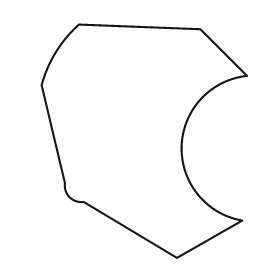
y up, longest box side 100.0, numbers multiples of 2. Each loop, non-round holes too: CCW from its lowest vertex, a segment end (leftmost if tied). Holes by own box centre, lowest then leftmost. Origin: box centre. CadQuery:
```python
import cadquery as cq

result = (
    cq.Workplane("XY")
    .moveTo(14.0, -50.0)
    .lineTo(42.0, -34.0)
    .threePointArc((16.0, -2.0), (44.0, 28.0))
    .lineTo(24.0, 48.0)
    .lineTo(-28.0, 50.0)
    .threePointArc((-38.0, 38.0), (-44.0, 24.0))
    .lineTo(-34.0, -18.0)
    .threePointArc((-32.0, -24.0), (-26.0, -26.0))
    .close()
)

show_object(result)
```